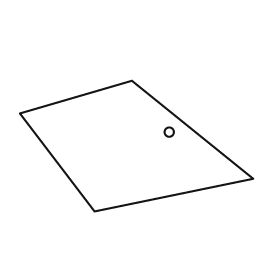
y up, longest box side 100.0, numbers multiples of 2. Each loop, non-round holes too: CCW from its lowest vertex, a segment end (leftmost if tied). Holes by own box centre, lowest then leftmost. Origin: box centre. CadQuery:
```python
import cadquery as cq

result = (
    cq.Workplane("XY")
    .moveTo(-18.0, -28.0)
    .lineTo(50.0, -14.0)
    .lineTo(-2.0, 28.0)
    .lineTo(-50.0, 14.0)
    .close()
    .moveTo(14.0, 6.0)
    .circle(2.0)
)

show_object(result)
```